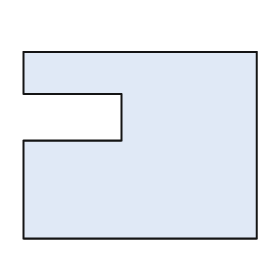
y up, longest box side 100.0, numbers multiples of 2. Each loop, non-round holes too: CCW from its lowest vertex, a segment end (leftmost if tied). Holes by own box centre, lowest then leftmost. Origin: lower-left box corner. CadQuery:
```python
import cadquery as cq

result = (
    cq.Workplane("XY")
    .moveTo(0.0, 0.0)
    .lineTo(100.0, 0.0)
    .lineTo(100.0, 80.0)
    .lineTo(0.0, 80.0)
    .lineTo(0.0, 62.0)
    .lineTo(42.0, 62.0)
    .lineTo(42.0, 42.0)
    .lineTo(0.0, 42.0)
    .close()
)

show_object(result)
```